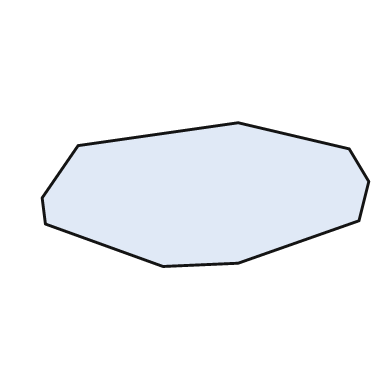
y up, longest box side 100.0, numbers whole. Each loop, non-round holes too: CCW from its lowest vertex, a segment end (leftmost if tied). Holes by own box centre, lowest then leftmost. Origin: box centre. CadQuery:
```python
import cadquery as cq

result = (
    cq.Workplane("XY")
    .moveTo(-13.0, -22.0)
    .lineTo(10.0, -21.0)
    .lineTo(47.0, -8.0)
    .lineTo(50.0, 4.0)
    .lineTo(44.0, 14.0)
    .lineTo(10.0, 22.0)
    .lineTo(-39.0, 15.0)
    .lineTo(-50.0, -1.0)
    .lineTo(-49.0, -9.0)
    .close()
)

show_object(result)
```